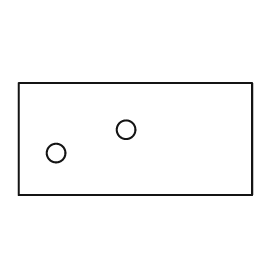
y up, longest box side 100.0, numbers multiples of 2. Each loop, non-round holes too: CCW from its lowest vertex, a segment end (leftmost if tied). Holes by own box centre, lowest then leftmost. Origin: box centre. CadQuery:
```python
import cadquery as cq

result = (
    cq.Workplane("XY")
    .moveTo(-50.0, -24.0)
    .lineTo(50.0, -24.0)
    .lineTo(50.0, 24.0)
    .lineTo(-50.0, 24.0)
    .close()
    .moveTo(-34.0, -6.0)
    .circle(4.0)
    .moveTo(-4.0, 4.0)
    .circle(4.0)
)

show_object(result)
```